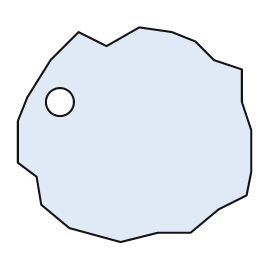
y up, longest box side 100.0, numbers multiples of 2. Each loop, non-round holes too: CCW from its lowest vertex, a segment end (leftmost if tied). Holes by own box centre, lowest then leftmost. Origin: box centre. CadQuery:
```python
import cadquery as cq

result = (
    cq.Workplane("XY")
    .moveTo(-6.0, -46.0)
    .lineTo(10.0, -42.0)
    .lineTo(24.0, -42.0)
    .lineTo(36.0, -32.0)
    .lineTo(48.0, -26.0)
    .lineTo(50.0, -16.0)
    .lineTo(50.0, 2.0)
    .lineTo(46.0, 14.0)
    .lineTo(46.0, 28.0)
    .lineTo(34.0, 32.0)
    .lineTo(26.0, 40.0)
    .lineTo(16.0, 44.0)
    .lineTo(2.0, 46.0)
    .lineTo(-12.0, 38.0)
    .lineTo(-24.0, 44.0)
    .lineTo(-36.0, 32.0)
    .lineTo(-46.0, 16.0)
    .lineTo(-50.0, 6.0)
    .lineTo(-50.0, -12.0)
    .lineTo(-42.0, -18.0)
    .lineTo(-40.0, -30.0)
    .lineTo(-28.0, -40.0)
    .close()
    .moveTo(-32.0, 14.0)
    .circle(6.0)
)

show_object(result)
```